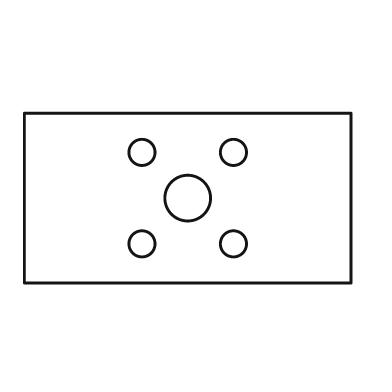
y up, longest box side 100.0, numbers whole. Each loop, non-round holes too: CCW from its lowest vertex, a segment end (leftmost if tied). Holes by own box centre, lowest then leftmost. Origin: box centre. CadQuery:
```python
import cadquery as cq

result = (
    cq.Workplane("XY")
    .moveTo(-50.0, -26.0)
    .lineTo(50.0, -26.0)
    .lineTo(50.0, 26.0)
    .lineTo(-50.0, 26.0)
    .close()
    .moveTo(-14.0, -14.0)
    .circle(4.0)
    .moveTo(14.0, -14.0)
    .circle(4.0)
    .moveTo(0.0, 0.0)
    .circle(7.0)
    .moveTo(-14.0, 14.0)
    .circle(4.0)
    .moveTo(14.0, 14.0)
    .circle(4.0)
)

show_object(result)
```